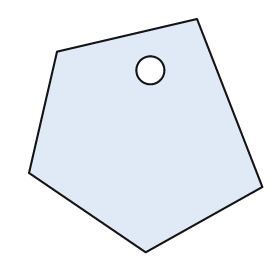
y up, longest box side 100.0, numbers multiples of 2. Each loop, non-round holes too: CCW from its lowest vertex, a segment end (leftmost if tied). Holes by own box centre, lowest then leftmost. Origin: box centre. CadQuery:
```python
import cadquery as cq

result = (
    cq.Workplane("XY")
    .moveTo(0.0, -50.0)
    .lineTo(50.0, -22.0)
    .lineTo(22.0, 50.0)
    .lineTo(-38.0, 36.0)
    .lineTo(-50.0, -16.0)
    .close()
    .moveTo(2.0, 28.0)
    .circle(6.0)
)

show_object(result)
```